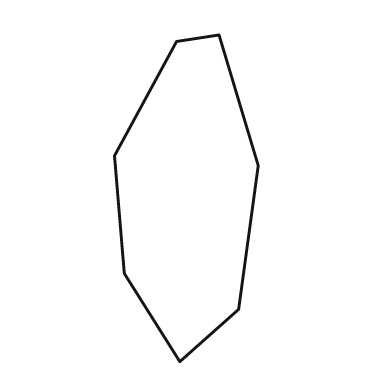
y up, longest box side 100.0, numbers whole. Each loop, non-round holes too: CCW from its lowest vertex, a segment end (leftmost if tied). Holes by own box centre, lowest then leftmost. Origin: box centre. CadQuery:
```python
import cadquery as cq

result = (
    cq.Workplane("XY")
    .moveTo(-2.0, -50.0)
    .lineTo(16.0, -34.0)
    .lineTo(22.0, 10.0)
    .lineTo(10.0, 50.0)
    .lineTo(-3.0, 48.0)
    .lineTo(-22.0, 13.0)
    .lineTo(-19.0, -23.0)
    .close()
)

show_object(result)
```